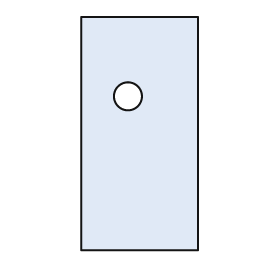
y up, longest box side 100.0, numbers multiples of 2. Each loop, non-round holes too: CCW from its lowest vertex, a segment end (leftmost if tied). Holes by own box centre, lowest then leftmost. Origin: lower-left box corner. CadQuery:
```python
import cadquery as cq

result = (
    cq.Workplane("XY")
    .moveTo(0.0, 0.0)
    .lineTo(50.0, 0.0)
    .lineTo(50.0, 100.0)
    .lineTo(0.0, 100.0)
    .close()
    .moveTo(20.0, 66.0)
    .circle(6.0)
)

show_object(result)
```